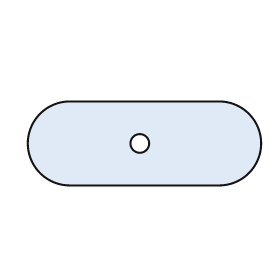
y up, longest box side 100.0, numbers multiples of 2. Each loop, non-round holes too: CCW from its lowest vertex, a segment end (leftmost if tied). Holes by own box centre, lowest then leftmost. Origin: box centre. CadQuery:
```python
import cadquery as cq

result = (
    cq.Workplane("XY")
    .moveTo(-32.0, -18.0)
    .lineTo(32.0, -18.0)
    .threePointArc((50.0, 0.0), (32.0, 18.0))
    .lineTo(-32.0, 18.0)
    .threePointArc((-50.0, 0.0), (-32.0, -18.0))
    .close()
    .moveTo(-2.0, 0.0)
    .circle(4.0)
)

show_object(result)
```